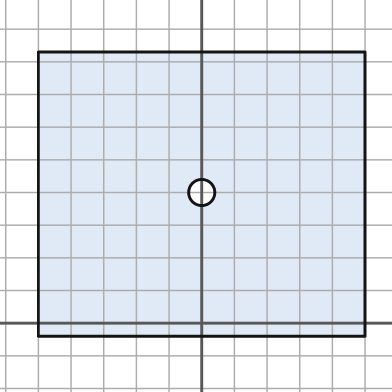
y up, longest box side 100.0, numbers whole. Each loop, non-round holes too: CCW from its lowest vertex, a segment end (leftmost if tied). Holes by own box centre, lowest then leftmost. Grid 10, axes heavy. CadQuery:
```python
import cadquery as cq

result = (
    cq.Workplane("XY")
    .moveTo(-50.0, -4.0)
    .lineTo(50.0, -4.0)
    .lineTo(50.0, 83.0)
    .lineTo(-50.0, 83.0)
    .close()
    .moveTo(0.0, 40.0)
    .circle(4.0)
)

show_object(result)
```